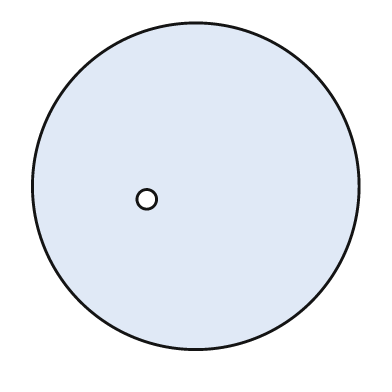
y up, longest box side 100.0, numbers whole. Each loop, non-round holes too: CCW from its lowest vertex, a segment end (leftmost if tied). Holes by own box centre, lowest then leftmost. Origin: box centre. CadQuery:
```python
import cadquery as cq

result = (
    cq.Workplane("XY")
    .moveTo(0.0, 0.0)
    .circle(50.0)
    .moveTo(-15.0, -4.0)
    .circle(3.0)
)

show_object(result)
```